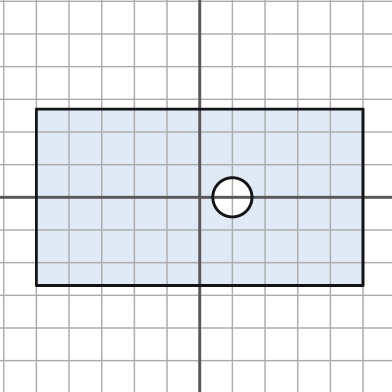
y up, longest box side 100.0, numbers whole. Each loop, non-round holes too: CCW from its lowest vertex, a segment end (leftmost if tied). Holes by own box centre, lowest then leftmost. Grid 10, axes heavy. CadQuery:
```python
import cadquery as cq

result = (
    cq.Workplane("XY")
    .moveTo(-50.0, -27.0)
    .lineTo(50.0, -27.0)
    .lineTo(50.0, 27.0)
    .lineTo(-50.0, 27.0)
    .close()
    .moveTo(10.0, 0.0)
    .circle(6.0)
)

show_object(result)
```